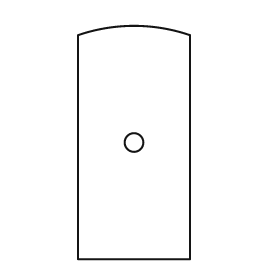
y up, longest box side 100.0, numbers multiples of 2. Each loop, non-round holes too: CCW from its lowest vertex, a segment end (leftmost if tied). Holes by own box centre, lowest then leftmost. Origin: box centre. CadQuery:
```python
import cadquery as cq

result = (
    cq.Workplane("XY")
    .moveTo(-24.0, -50.0)
    .lineTo(24.0, -50.0)
    .lineTo(24.0, 46.0)
    .threePointArc((0.0, 50.0), (-24.0, 46.0))
    .close()
    .moveTo(0.0, 0.0)
    .circle(4.0)
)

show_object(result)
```